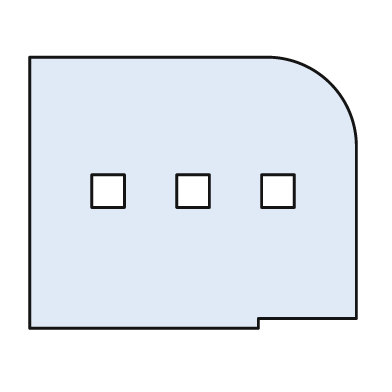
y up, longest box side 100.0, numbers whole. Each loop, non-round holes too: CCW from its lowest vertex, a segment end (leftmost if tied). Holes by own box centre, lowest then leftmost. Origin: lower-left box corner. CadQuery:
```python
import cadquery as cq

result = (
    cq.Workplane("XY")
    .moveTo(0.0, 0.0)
    .lineTo(70.0, 0.0)
    .lineTo(70.0, 3.0)
    .lineTo(100.0, 3.0)
    .lineTo(100.0, 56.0)
    .threePointArc((92.0, 75.0), (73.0, 83.0))
    .lineTo(0.0, 83.0)
    .close()
    .moveTo(19.0, 37.0)
    .lineTo(29.0, 37.0)
    .lineTo(29.0, 47.0)
    .lineTo(19.0, 47.0)
    .close()
    .moveTo(45.0, 37.0)
    .lineTo(55.0, 37.0)
    .lineTo(55.0, 47.0)
    .lineTo(45.0, 47.0)
    .close()
    .moveTo(71.0, 37.0)
    .lineTo(81.0, 37.0)
    .lineTo(81.0, 47.0)
    .lineTo(71.0, 47.0)
    .close()
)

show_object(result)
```